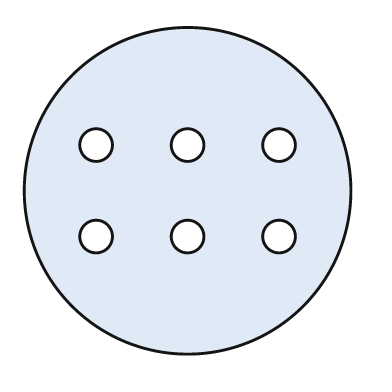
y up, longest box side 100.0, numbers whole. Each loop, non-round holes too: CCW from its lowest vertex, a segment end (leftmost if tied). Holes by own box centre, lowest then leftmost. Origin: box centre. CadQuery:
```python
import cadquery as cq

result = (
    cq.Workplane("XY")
    .moveTo(0.0, 0.0)
    .circle(50.0)
    .moveTo(-28.0, -14.0)
    .circle(5.0)
    .moveTo(0.0, -14.0)
    .circle(5.0)
    .moveTo(28.0, -14.0)
    .circle(5.0)
    .moveTo(-28.0, 14.0)
    .circle(5.0)
    .moveTo(0.0, 14.0)
    .circle(5.0)
    .moveTo(28.0, 14.0)
    .circle(5.0)
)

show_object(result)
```